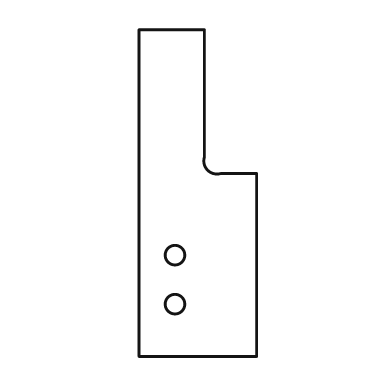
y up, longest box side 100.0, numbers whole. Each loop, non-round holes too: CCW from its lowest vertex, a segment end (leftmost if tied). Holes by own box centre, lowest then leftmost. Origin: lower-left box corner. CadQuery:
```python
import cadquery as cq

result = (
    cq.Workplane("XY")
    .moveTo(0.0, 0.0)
    .lineTo(36.0, 0.0)
    .lineTo(36.0, 56.0)
    .lineTo(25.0, 56.0)
    .threePointArc((21.0, 57.0), (20.0, 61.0))
    .lineTo(20.0, 100.0)
    .lineTo(0.0, 100.0)
    .close()
    .moveTo(11.0, 16.0)
    .circle(3.0)
    .moveTo(11.0, 31.0)
    .circle(3.0)
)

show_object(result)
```